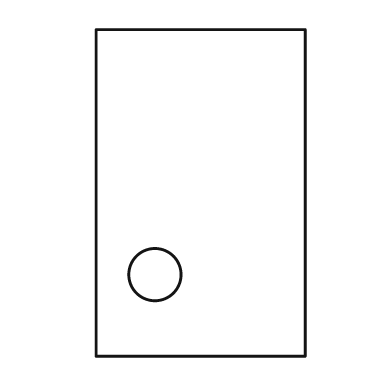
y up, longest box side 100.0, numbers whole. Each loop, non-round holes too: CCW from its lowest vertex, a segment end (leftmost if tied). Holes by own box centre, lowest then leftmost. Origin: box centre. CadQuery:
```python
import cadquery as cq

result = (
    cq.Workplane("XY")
    .moveTo(-32.0, -50.0)
    .lineTo(32.0, -50.0)
    .lineTo(32.0, 50.0)
    .lineTo(-32.0, 50.0)
    .close()
    .moveTo(-14.0, -25.0)
    .circle(8.0)
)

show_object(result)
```